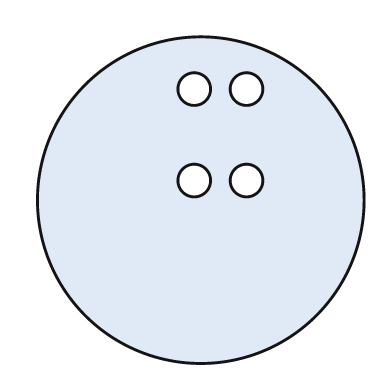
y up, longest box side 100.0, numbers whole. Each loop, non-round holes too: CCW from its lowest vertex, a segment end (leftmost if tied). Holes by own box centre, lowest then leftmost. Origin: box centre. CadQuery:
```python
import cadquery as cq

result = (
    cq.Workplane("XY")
    .moveTo(0.0, 0.0)
    .circle(50.0)
    .moveTo(-2.0, 6.0)
    .circle(5.0)
    .moveTo(14.0, 6.0)
    .circle(5.0)
    .moveTo(-2.0, 34.0)
    .circle(5.0)
    .moveTo(14.0, 34.0)
    .circle(5.0)
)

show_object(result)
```